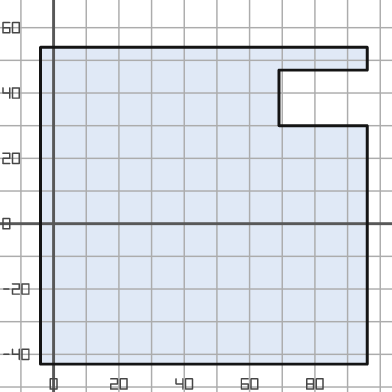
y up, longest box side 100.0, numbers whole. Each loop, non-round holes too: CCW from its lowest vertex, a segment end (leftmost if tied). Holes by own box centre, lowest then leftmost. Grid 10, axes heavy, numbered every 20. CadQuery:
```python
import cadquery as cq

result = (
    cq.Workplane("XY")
    .moveTo(-4.0, -43.0)
    .lineTo(96.0, -43.0)
    .lineTo(96.0, 30.0)
    .lineTo(69.0, 30.0)
    .lineTo(69.0, 47.0)
    .lineTo(96.0, 47.0)
    .lineTo(96.0, 54.0)
    .lineTo(-4.0, 54.0)
    .close()
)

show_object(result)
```